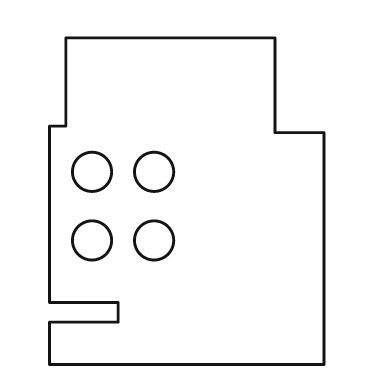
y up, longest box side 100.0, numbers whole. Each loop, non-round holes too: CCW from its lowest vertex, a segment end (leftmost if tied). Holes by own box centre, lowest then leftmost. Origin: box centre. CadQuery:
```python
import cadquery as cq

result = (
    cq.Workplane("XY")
    .moveTo(-42.0, -50.0)
    .lineTo(42.0, -50.0)
    .lineTo(42.0, 21.0)
    .lineTo(27.0, 21.0)
    .lineTo(27.0, 50.0)
    .lineTo(-37.0, 50.0)
    .lineTo(-37.0, 23.0)
    .lineTo(-42.0, 23.0)
    .lineTo(-42.0, -31.0)
    .lineTo(-21.0, -31.0)
    .lineTo(-21.0, -37.0)
    .lineTo(-42.0, -37.0)
    .close()
    .moveTo(-29.0, -12.0)
    .circle(6.0)
    .moveTo(-10.0, -12.0)
    .circle(6.0)
    .moveTo(-29.0, 9.0)
    .circle(6.0)
    .moveTo(-10.0, 9.0)
    .circle(6.0)
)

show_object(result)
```